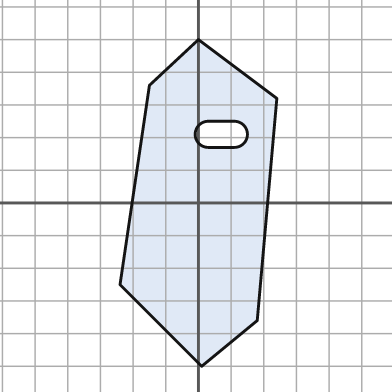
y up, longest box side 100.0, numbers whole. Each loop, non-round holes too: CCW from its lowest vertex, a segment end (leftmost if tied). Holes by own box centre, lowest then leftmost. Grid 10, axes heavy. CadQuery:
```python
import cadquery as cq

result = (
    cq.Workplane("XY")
    .moveTo(1.0, -50.0)
    .lineTo(18.0, -36.0)
    .lineTo(24.0, 32.0)
    .lineTo(0.0, 50.0)
    .lineTo(-15.0, 36.0)
    .lineTo(-24.0, -25.0)
    .close()
    .moveTo(3.0, 17.0)
    .lineTo(11.0, 17.0)
    .threePointArc((15.0, 21.0), (11.0, 25.0))
    .lineTo(3.0, 25.0)
    .threePointArc((-1.0, 21.0), (3.0, 17.0))
    .close()
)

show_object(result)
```